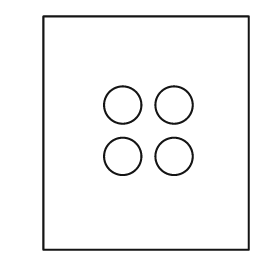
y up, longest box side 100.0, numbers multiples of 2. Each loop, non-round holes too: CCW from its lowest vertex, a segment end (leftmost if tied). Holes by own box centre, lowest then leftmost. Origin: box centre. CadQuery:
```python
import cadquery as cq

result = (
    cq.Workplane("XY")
    .moveTo(-44.0, -50.0)
    .lineTo(44.0, -50.0)
    .lineTo(44.0, 50.0)
    .lineTo(-44.0, 50.0)
    .close()
    .moveTo(-10.0, -10.0)
    .circle(8.0)
    .moveTo(12.0, -10.0)
    .circle(8.0)
    .moveTo(-10.0, 12.0)
    .circle(8.0)
    .moveTo(12.0, 12.0)
    .circle(8.0)
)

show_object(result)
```